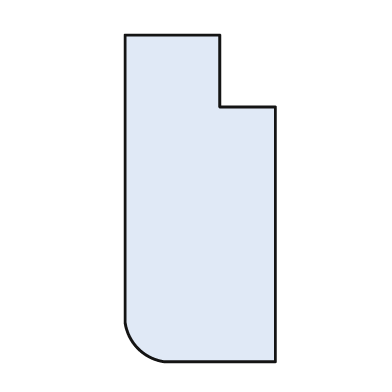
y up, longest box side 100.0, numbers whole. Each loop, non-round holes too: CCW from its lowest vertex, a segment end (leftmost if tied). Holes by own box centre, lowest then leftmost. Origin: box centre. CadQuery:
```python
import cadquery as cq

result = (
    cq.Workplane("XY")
    .moveTo(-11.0, -50.0)
    .lineTo(23.0, -50.0)
    .lineTo(23.0, 28.0)
    .lineTo(6.0, 28.0)
    .lineTo(6.0, 50.0)
    .lineTo(-23.0, 50.0)
    .lineTo(-23.0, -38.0)
    .threePointArc((-19.0, -46.0), (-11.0, -50.0))
    .close()
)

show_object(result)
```